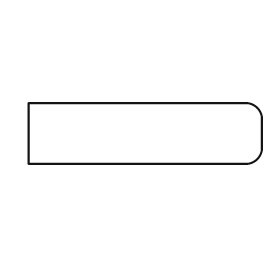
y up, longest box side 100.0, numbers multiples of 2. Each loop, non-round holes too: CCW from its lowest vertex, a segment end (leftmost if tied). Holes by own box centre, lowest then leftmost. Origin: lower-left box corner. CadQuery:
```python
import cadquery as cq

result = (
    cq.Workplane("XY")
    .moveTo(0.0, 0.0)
    .lineTo(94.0, 0.0)
    .threePointArc((98.0, 2.0), (100.0, 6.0))
    .lineTo(100.0, 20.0)
    .threePointArc((98.0, 24.0), (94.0, 26.0))
    .lineTo(0.0, 26.0)
    .close()
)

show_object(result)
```